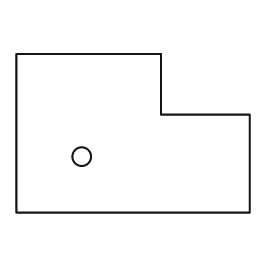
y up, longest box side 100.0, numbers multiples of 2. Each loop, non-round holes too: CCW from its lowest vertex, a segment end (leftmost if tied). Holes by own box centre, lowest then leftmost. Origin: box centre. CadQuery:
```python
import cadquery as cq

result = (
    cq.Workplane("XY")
    .moveTo(-50.0, -34.0)
    .lineTo(50.0, -34.0)
    .lineTo(50.0, 8.0)
    .lineTo(12.0, 8.0)
    .lineTo(12.0, 34.0)
    .lineTo(-50.0, 34.0)
    .close()
    .moveTo(-22.0, -10.0)
    .circle(4.0)
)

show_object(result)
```